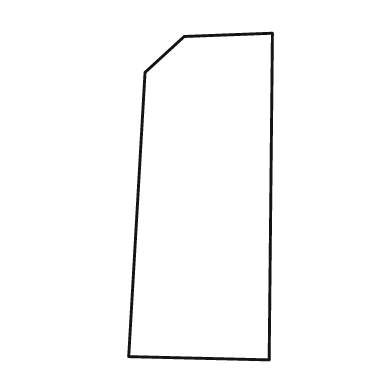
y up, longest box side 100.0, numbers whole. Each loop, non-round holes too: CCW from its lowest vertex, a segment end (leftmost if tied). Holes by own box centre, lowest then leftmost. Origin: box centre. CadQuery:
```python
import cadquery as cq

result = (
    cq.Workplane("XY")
    .moveTo(21.0, -50.0)
    .lineTo(22.0, 50.0)
    .lineTo(-5.0, 49.0)
    .lineTo(-17.0, 38.0)
    .lineTo(-22.0, -49.0)
    .close()
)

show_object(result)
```